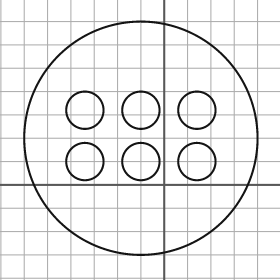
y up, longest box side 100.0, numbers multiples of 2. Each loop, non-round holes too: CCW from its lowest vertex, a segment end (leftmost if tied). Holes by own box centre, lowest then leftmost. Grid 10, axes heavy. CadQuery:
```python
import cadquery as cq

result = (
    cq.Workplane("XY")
    .moveTo(-10.0, 20.0)
    .circle(50.0)
    .moveTo(-34.0, 10.0)
    .circle(8.0)
    .moveTo(-10.0, 10.0)
    .circle(8.0)
    .moveTo(14.0, 10.0)
    .circle(8.0)
    .moveTo(-34.0, 32.0)
    .circle(8.0)
    .moveTo(-10.0, 32.0)
    .circle(8.0)
    .moveTo(14.0, 32.0)
    .circle(8.0)
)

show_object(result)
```